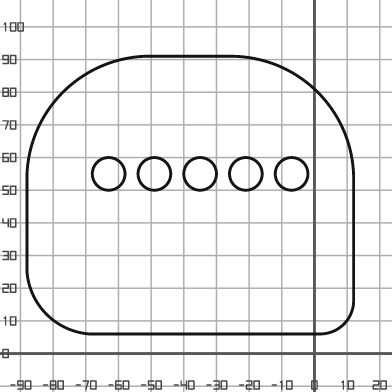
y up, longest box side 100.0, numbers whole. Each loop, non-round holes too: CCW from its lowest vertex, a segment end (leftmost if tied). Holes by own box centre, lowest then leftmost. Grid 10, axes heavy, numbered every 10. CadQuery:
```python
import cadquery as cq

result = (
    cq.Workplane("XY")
    .moveTo(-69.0, 6.0)
    .lineTo(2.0, 6.0)
    .threePointArc((9.0, 9.0), (12.0, 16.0))
    .lineTo(12.0, 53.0)
    .threePointArc((1.0, 80.0), (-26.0, 91.0))
    .lineTo(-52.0, 91.0)
    .threePointArc((-77.0, 80.0), (-88.0, 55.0))
    .lineTo(-88.0, 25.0)
    .threePointArc((-82.0, 12.0), (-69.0, 6.0))
    .close()
    .moveTo(-63.0, 55.0)
    .circle(5.0)
    .moveTo(-49.0, 55.0)
    .circle(5.0)
    .moveTo(-35.0, 55.0)
    .circle(5.0)
    .moveTo(-21.0, 55.0)
    .circle(5.0)
    .moveTo(-7.0, 55.0)
    .circle(5.0)
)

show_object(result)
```